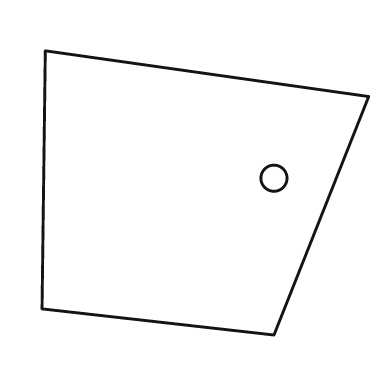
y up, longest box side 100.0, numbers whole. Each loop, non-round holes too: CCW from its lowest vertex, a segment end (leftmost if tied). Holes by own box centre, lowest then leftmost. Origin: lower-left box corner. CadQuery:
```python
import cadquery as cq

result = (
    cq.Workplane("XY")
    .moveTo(71.0, 0.0)
    .lineTo(100.0, 73.0)
    .lineTo(1.0, 87.0)
    .lineTo(0.0, 8.0)
    .close()
    .moveTo(71.0, 48.0)
    .circle(4.0)
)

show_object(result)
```